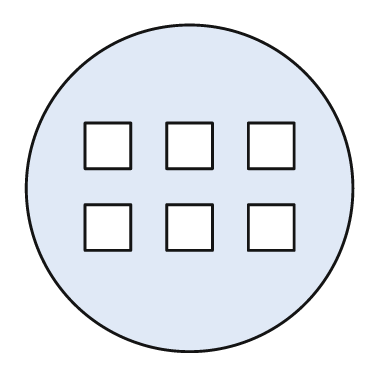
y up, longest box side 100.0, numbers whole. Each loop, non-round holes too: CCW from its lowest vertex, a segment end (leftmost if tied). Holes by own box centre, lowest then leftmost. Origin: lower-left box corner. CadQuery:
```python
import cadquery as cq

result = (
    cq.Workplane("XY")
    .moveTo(50.0, 50.0)
    .circle(50.0)
    .moveTo(18.0, 31.0)
    .lineTo(32.0, 31.0)
    .lineTo(32.0, 45.0)
    .lineTo(18.0, 45.0)
    .close()
    .moveTo(43.0, 31.0)
    .lineTo(57.0, 31.0)
    .lineTo(57.0, 45.0)
    .lineTo(43.0, 45.0)
    .close()
    .moveTo(68.0, 31.0)
    .lineTo(82.0, 31.0)
    .lineTo(82.0, 45.0)
    .lineTo(68.0, 45.0)
    .close()
    .moveTo(18.0, 56.0)
    .lineTo(32.0, 56.0)
    .lineTo(32.0, 70.0)
    .lineTo(18.0, 70.0)
    .close()
    .moveTo(43.0, 56.0)
    .lineTo(57.0, 56.0)
    .lineTo(57.0, 70.0)
    .lineTo(43.0, 70.0)
    .close()
    .moveTo(68.0, 56.0)
    .lineTo(82.0, 56.0)
    .lineTo(82.0, 70.0)
    .lineTo(68.0, 70.0)
    .close()
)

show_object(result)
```